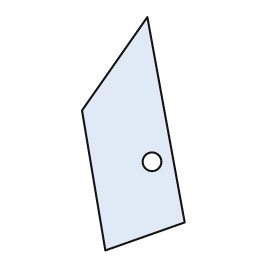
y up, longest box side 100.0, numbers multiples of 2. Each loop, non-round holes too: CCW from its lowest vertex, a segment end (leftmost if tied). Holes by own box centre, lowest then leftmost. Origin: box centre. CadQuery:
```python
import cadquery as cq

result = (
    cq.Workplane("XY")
    .moveTo(-12.0, -50.0)
    .lineTo(22.0, -38.0)
    .lineTo(6.0, 50.0)
    .lineTo(-22.0, 10.0)
    .close()
    .moveTo(8.0, -12.0)
    .circle(4.0)
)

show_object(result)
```